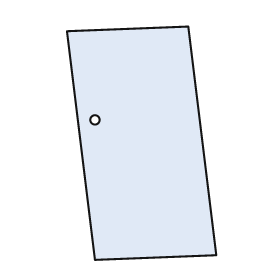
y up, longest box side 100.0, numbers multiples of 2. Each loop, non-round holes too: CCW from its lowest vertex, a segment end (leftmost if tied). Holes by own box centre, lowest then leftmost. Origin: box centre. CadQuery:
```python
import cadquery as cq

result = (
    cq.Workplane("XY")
    .moveTo(-20.0, -50.0)
    .lineTo(32.0, -48.0)
    .lineTo(20.0, 50.0)
    .lineTo(-32.0, 48.0)
    .close()
    .moveTo(-20.0, 10.0)
    .circle(2.0)
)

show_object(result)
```